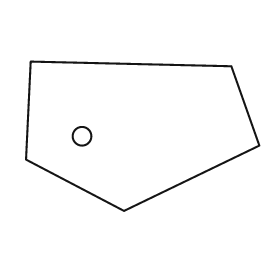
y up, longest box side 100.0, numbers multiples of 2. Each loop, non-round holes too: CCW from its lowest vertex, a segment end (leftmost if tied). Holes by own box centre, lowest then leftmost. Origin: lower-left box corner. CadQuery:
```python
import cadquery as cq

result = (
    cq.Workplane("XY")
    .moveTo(42.0, 0.0)
    .lineTo(100.0, 28.0)
    .lineTo(88.0, 62.0)
    .lineTo(2.0, 64.0)
    .lineTo(0.0, 22.0)
    .close()
    .moveTo(24.0, 32.0)
    .circle(4.0)
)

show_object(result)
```